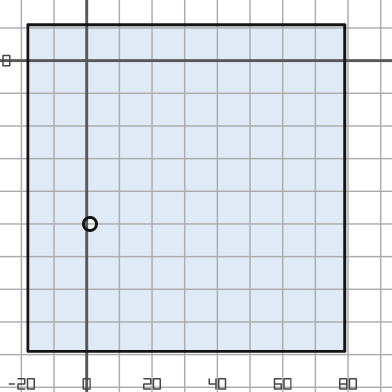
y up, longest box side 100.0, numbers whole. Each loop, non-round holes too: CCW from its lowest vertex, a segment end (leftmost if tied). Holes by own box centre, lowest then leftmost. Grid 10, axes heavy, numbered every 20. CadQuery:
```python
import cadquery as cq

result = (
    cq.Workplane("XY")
    .moveTo(-18.0, -89.0)
    .lineTo(79.0, -89.0)
    .lineTo(79.0, 11.0)
    .lineTo(-18.0, 11.0)
    .close()
    .moveTo(1.0, -50.0)
    .circle(2.0)
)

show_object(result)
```